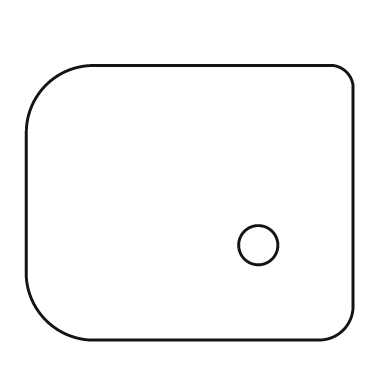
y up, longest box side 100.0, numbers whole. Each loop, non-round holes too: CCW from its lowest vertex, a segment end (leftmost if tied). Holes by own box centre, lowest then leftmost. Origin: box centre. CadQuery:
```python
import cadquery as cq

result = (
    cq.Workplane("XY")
    .moveTo(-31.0, -42.0)
    .lineTo(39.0, -42.0)
    .threePointArc((47.0, -39.0), (50.0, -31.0))
    .lineTo(50.0, 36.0)
    .threePointArc((48.0, 40.0), (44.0, 42.0))
    .lineTo(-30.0, 42.0)
    .threePointArc((-44.0, 36.0), (-50.0, 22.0))
    .lineTo(-50.0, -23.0)
    .threePointArc((-44.0, -36.0), (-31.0, -42.0))
    .close()
    .moveTo(21.0, -13.0)
    .circle(6.0)
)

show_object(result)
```